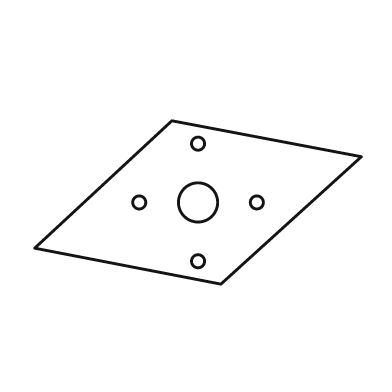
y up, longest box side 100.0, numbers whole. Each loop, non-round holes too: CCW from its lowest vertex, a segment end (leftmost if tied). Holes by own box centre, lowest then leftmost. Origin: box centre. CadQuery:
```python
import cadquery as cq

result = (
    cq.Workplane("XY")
    .moveTo(7.0, -25.0)
    .lineTo(50.0, 14.0)
    .lineTo(-8.0, 25.0)
    .lineTo(-50.0, -14.0)
    .close()
    .moveTo(0.0, -18.0)
    .circle(2.0)
    .moveTo(-18.0, 0.0)
    .circle(2.0)
    .moveTo(0.0, 0.0)
    .circle(6.0)
    .moveTo(18.0, 0.0)
    .circle(2.0)
    .moveTo(0.0, 18.0)
    .circle(2.0)
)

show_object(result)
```